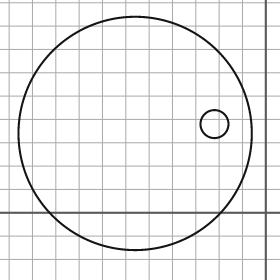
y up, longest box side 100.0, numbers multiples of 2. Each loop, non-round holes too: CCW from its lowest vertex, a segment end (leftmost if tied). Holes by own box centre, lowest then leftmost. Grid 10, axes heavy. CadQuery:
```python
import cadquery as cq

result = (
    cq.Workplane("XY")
    .moveTo(-56.0, 34.0)
    .circle(50.0)
    .moveTo(-22.0, 38.0)
    .circle(6.0)
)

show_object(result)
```